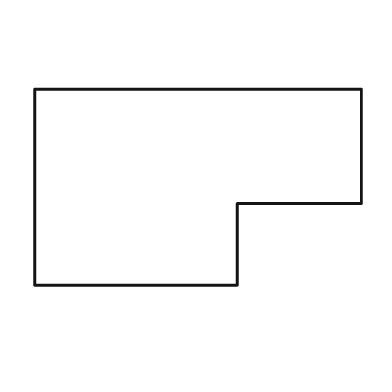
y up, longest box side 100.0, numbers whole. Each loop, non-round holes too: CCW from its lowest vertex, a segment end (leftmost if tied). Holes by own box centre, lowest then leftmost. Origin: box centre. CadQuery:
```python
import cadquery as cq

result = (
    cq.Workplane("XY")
    .moveTo(-50.0, -30.0)
    .lineTo(12.0, -30.0)
    .lineTo(12.0, -5.0)
    .lineTo(50.0, -5.0)
    .lineTo(50.0, 30.0)
    .lineTo(-50.0, 30.0)
    .close()
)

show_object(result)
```